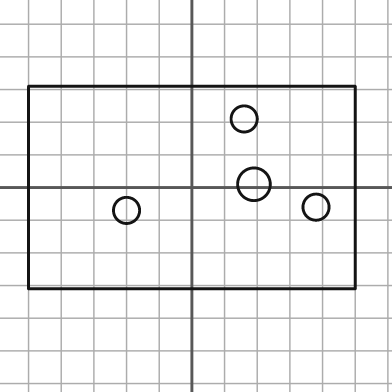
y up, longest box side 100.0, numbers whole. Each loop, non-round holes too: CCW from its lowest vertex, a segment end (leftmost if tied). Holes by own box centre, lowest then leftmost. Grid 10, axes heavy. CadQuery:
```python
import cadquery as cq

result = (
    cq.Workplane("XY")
    .moveTo(-50.0, -31.0)
    .lineTo(50.0, -31.0)
    .lineTo(50.0, 31.0)
    .lineTo(-50.0, 31.0)
    .close()
    .moveTo(-20.0, -7.0)
    .circle(4.0)
    .moveTo(38.0, -6.0)
    .circle(4.0)
    .moveTo(19.0, 1.0)
    .circle(5.0)
    .moveTo(16.0, 21.0)
    .circle(4.0)
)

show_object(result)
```